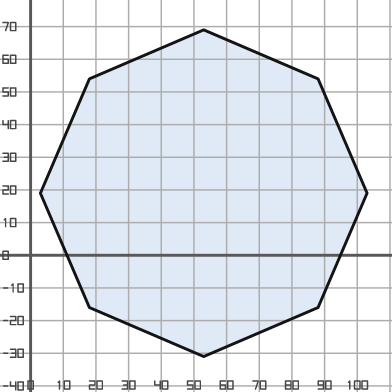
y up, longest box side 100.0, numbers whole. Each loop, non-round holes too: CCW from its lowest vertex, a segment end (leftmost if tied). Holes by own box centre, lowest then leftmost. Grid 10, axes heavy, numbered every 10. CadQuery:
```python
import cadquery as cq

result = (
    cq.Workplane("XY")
    .moveTo(53.0, -31.0)
    .lineTo(88.0, -16.0)
    .lineTo(103.0, 19.0)
    .lineTo(88.0, 54.0)
    .lineTo(53.0, 69.0)
    .lineTo(18.0, 54.0)
    .lineTo(3.0, 19.0)
    .lineTo(18.0, -16.0)
    .close()
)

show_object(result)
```